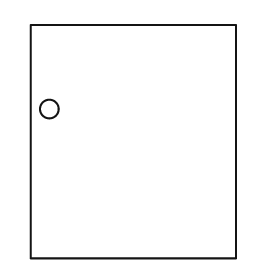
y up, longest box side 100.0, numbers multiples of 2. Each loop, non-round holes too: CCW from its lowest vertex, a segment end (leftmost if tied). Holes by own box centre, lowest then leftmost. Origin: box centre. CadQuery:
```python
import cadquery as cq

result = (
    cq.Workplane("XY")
    .moveTo(-44.0, -50.0)
    .lineTo(44.0, -50.0)
    .lineTo(44.0, 50.0)
    .lineTo(-44.0, 50.0)
    .close()
    .moveTo(-36.0, 14.0)
    .circle(4.0)
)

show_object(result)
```